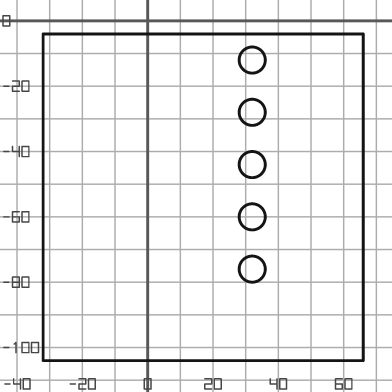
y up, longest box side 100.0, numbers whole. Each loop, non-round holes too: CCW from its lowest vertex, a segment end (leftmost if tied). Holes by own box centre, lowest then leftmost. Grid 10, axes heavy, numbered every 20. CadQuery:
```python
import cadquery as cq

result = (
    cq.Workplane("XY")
    .moveTo(-32.0, -104.0)
    .lineTo(66.0, -104.0)
    .lineTo(66.0, -4.0)
    .lineTo(-32.0, -4.0)
    .close()
    .moveTo(32.0, -76.0)
    .circle(4.0)
    .moveTo(32.0, -60.0)
    .circle(4.0)
    .moveTo(32.0, -44.0)
    .circle(4.0)
    .moveTo(32.0, -28.0)
    .circle(4.0)
    .moveTo(32.0, -12.0)
    .circle(4.0)
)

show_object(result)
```